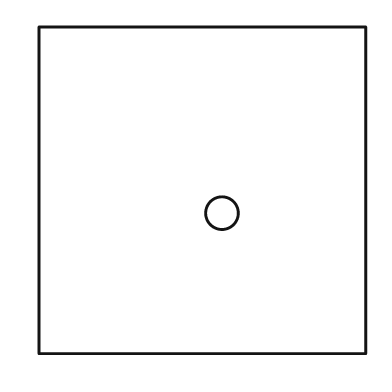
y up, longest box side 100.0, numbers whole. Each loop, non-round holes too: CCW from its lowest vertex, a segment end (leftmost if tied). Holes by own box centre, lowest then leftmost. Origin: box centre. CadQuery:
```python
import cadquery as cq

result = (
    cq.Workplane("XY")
    .moveTo(-50.0, -50.0)
    .lineTo(50.0, -50.0)
    .lineTo(50.0, 50.0)
    .lineTo(-50.0, 50.0)
    .close()
    .moveTo(6.0, -7.0)
    .circle(5.0)
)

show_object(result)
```